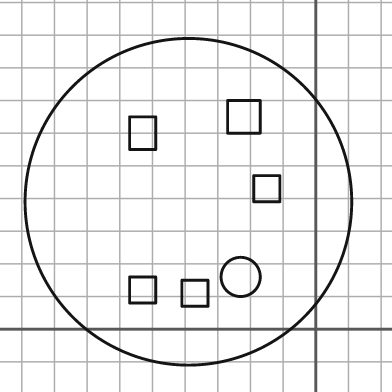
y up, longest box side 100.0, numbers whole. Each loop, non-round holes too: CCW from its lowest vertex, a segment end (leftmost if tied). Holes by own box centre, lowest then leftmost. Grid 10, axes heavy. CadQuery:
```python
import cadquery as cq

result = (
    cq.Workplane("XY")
    .moveTo(-39.0, 39.0)
    .circle(50.0)
    .moveTo(-41.0, 7.0)
    .lineTo(-33.0, 7.0)
    .lineTo(-33.0, 15.0)
    .lineTo(-41.0, 15.0)
    .close()
    .moveTo(-57.0, 8.0)
    .lineTo(-49.0, 8.0)
    .lineTo(-49.0, 16.0)
    .lineTo(-57.0, 16.0)
    .close()
    .moveTo(-23.0, 16.0)
    .circle(6.0)
    .moveTo(-19.0, 39.0)
    .lineTo(-11.0, 39.0)
    .lineTo(-11.0, 47.0)
    .lineTo(-19.0, 47.0)
    .close()
    .moveTo(-57.0, 55.0)
    .lineTo(-49.0, 55.0)
    .lineTo(-49.0, 65.0)
    .lineTo(-57.0, 65.0)
    .close()
    .moveTo(-27.0, 60.0)
    .lineTo(-17.0, 60.0)
    .lineTo(-17.0, 70.0)
    .lineTo(-27.0, 70.0)
    .close()
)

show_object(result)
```